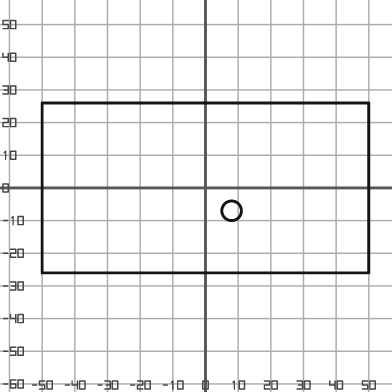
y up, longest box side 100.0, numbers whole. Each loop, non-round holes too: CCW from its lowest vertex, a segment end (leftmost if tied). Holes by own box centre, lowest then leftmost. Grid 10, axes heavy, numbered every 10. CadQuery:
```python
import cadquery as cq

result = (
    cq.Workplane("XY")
    .moveTo(-50.0, -26.0)
    .lineTo(50.0, -26.0)
    .lineTo(50.0, 26.0)
    .lineTo(-50.0, 26.0)
    .close()
    .moveTo(8.0, -7.0)
    .circle(3.0)
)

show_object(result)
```